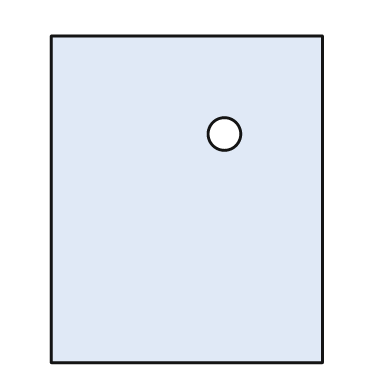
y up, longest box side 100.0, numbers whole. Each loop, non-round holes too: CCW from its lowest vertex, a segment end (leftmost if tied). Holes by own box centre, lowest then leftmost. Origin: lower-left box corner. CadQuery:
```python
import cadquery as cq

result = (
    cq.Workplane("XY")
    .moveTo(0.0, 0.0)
    .lineTo(83.0, 0.0)
    .lineTo(83.0, 100.0)
    .lineTo(0.0, 100.0)
    .close()
    .moveTo(53.0, 70.0)
    .circle(5.0)
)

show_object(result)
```